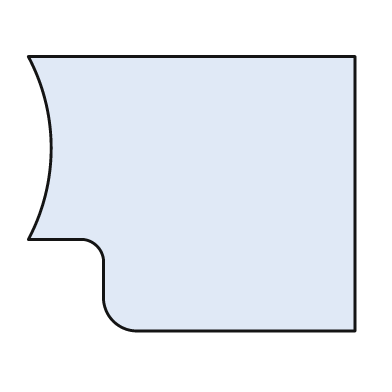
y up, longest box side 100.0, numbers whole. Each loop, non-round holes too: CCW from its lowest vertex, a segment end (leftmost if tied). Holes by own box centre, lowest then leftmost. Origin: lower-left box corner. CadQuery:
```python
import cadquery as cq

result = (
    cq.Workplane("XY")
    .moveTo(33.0, 0.0)
    .lineTo(100.0, 0.0)
    .lineTo(100.0, 84.0)
    .lineTo(0.0, 84.0)
    .threePointArc((7.0, 56.0), (0.0, 28.0))
    .lineTo(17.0, 28.0)
    .threePointArc((21.0, 26.0), (23.0, 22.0))
    .lineTo(23.0, 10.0)
    .threePointArc((26.0, 3.0), (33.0, 0.0))
    .close()
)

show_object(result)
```